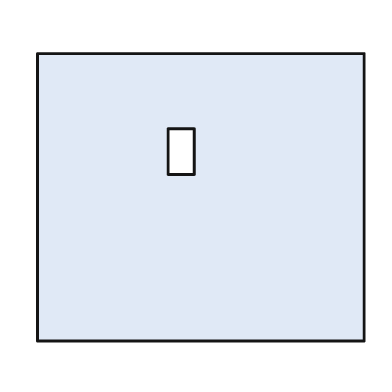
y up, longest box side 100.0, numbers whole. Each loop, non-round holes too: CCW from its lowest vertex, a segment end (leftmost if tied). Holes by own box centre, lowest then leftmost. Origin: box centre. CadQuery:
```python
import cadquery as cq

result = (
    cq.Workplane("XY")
    .moveTo(-50.0, -44.0)
    .lineTo(50.0, -44.0)
    .lineTo(50.0, 44.0)
    .lineTo(-50.0, 44.0)
    .close()
    .moveTo(-10.0, 7.0)
    .lineTo(-2.0, 7.0)
    .lineTo(-2.0, 21.0)
    .lineTo(-10.0, 21.0)
    .close()
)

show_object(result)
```